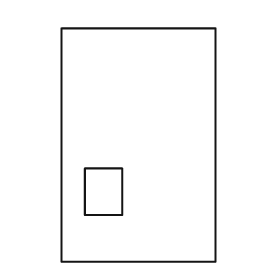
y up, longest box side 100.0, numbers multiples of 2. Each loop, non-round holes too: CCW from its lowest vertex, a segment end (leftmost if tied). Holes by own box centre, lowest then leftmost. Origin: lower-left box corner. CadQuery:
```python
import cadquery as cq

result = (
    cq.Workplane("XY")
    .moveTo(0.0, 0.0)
    .lineTo(66.0, 0.0)
    .lineTo(66.0, 100.0)
    .lineTo(0.0, 100.0)
    .close()
    .moveTo(10.0, 20.0)
    .lineTo(26.0, 20.0)
    .lineTo(26.0, 40.0)
    .lineTo(10.0, 40.0)
    .close()
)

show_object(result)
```